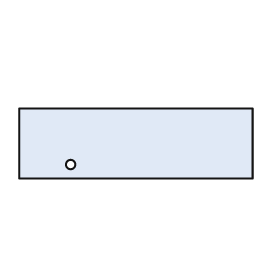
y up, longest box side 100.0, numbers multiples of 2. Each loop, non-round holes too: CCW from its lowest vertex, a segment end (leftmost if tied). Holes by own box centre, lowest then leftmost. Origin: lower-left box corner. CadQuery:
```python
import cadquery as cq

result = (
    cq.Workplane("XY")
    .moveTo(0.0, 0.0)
    .lineTo(100.0, 0.0)
    .lineTo(100.0, 30.0)
    .lineTo(0.0, 30.0)
    .close()
    .moveTo(22.0, 6.0)
    .circle(2.0)
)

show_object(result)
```